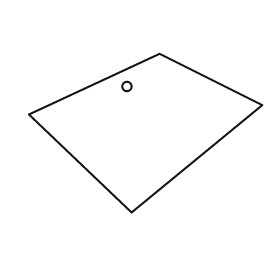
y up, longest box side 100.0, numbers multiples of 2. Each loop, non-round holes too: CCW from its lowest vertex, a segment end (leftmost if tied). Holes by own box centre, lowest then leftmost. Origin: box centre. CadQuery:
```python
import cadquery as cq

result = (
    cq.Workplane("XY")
    .moveTo(-6.0, -34.0)
    .lineTo(50.0, 12.0)
    .lineTo(6.0, 34.0)
    .lineTo(-50.0, 8.0)
    .close()
    .moveTo(-8.0, 20.0)
    .circle(2.0)
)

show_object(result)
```